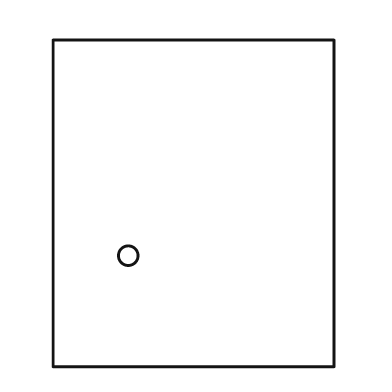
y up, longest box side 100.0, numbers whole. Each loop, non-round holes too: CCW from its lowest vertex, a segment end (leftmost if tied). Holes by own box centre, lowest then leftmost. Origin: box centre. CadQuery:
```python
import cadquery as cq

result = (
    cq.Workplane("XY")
    .moveTo(-43.0, -50.0)
    .lineTo(43.0, -50.0)
    .lineTo(43.0, 50.0)
    .lineTo(-43.0, 50.0)
    .close()
    .moveTo(-20.0, -16.0)
    .circle(3.0)
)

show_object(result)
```